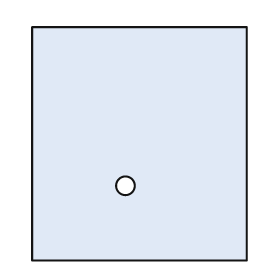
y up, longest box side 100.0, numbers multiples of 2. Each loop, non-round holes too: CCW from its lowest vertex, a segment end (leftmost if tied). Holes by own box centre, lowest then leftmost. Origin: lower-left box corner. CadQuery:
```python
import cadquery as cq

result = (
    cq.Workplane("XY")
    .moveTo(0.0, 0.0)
    .lineTo(92.0, 0.0)
    .lineTo(92.0, 100.0)
    .lineTo(0.0, 100.0)
    .close()
    .moveTo(40.0, 32.0)
    .circle(4.0)
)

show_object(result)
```